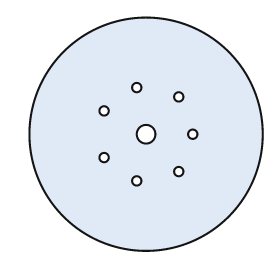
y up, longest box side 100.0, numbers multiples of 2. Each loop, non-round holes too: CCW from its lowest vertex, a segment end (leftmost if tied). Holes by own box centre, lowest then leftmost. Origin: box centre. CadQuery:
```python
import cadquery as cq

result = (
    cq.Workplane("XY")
    .moveTo(0.0, 0.0)
    .circle(50.0)
    .moveTo(-4.0, -20.0)
    .circle(2.0)
    .moveTo(14.0, -16.0)
    .circle(2.0)
    .moveTo(-18.0, -10.0)
    .circle(2.0)
    .moveTo(0.0, 0.0)
    .circle(4.0)
    .moveTo(20.0, 0.0)
    .circle(2.0)
    .moveTo(-18.0, 10.0)
    .circle(2.0)
    .moveTo(14.0, 16.0)
    .circle(2.0)
    .moveTo(-4.0, 20.0)
    .circle(2.0)
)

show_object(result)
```